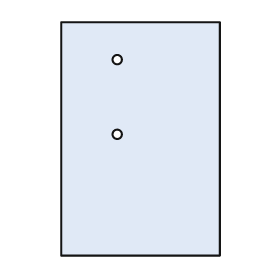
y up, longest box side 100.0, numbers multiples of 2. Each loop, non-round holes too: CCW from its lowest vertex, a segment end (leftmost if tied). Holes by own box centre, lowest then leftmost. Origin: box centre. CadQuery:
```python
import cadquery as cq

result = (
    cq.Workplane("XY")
    .moveTo(-34.0, -50.0)
    .lineTo(34.0, -50.0)
    .lineTo(34.0, 50.0)
    .lineTo(-34.0, 50.0)
    .close()
    .moveTo(-10.0, 2.0)
    .circle(2.0)
    .moveTo(-10.0, 34.0)
    .circle(2.0)
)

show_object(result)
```